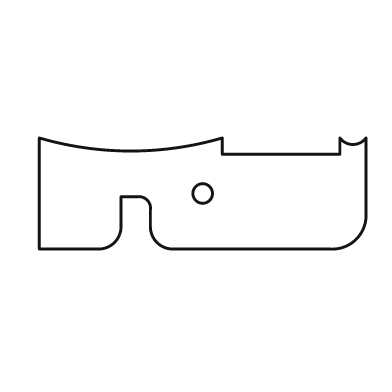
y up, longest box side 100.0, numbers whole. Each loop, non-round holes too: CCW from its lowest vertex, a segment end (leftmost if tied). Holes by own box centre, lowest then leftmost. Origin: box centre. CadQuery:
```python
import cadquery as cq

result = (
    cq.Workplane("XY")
    .moveTo(-50.0, -17.0)
    .lineTo(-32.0, -17.0)
    .threePointArc((-27.0, -15.0), (-25.0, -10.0))
    .lineTo(-25.0, -1.0)
    .lineTo(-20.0, -1.0)
    .threePointArc((-17.0, -2.0), (-16.0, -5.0))
    .lineTo(-16.0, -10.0)
    .threePointArc((-14.0, -15.0), (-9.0, -17.0))
    .lineTo(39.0, -17.0)
    .threePointArc((47.0, -14.0), (50.0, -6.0))
    .lineTo(50.0, 17.0)
    .threePointArc((46.0, 15.0), (42.0, 17.0))
    .lineTo(42.0, 12.0)
    .lineTo(6.0, 12.0)
    .lineTo(6.0, 17.0)
    .threePointArc((-22.0, 13.0), (-50.0, 17.0))
    .close()
    .moveTo(0.0, 0.0)
    .circle(3.0)
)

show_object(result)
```